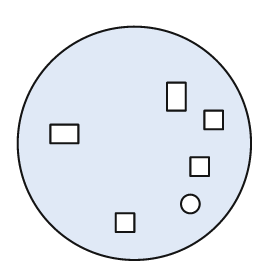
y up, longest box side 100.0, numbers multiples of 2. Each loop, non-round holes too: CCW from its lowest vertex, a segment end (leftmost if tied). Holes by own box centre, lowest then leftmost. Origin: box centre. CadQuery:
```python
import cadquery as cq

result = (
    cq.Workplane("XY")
    .moveTo(0.0, 0.0)
    .circle(50.0)
    .moveTo(-8.0, -38.0)
    .lineTo(0.0, -38.0)
    .lineTo(0.0, -30.0)
    .lineTo(-8.0, -30.0)
    .close()
    .moveTo(24.0, -26.0)
    .circle(4.0)
    .moveTo(24.0, -14.0)
    .lineTo(32.0, -14.0)
    .lineTo(32.0, -6.0)
    .lineTo(24.0, -6.0)
    .close()
    .moveTo(-36.0, 0.0)
    .lineTo(-24.0, 0.0)
    .lineTo(-24.0, 8.0)
    .lineTo(-36.0, 8.0)
    .close()
    .moveTo(30.0, 6.0)
    .lineTo(38.0, 6.0)
    .lineTo(38.0, 14.0)
    .lineTo(30.0, 14.0)
    .close()
    .moveTo(14.0, 14.0)
    .lineTo(22.0, 14.0)
    .lineTo(22.0, 26.0)
    .lineTo(14.0, 26.0)
    .close()
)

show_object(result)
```